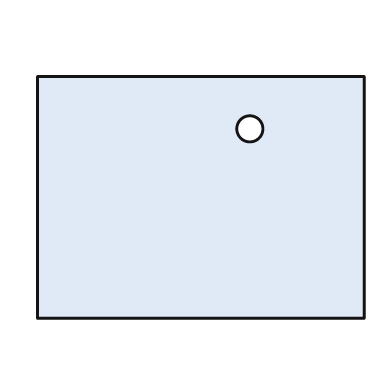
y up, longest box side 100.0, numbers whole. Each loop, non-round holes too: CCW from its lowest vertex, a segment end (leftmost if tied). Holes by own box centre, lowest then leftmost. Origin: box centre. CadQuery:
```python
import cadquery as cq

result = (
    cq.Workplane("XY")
    .moveTo(-50.0, -37.0)
    .lineTo(50.0, -37.0)
    .lineTo(50.0, 37.0)
    .lineTo(-50.0, 37.0)
    .close()
    .moveTo(15.0, 21.0)
    .circle(4.0)
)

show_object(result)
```